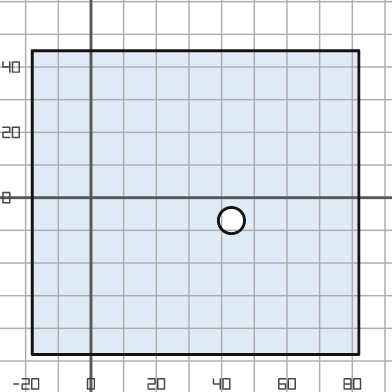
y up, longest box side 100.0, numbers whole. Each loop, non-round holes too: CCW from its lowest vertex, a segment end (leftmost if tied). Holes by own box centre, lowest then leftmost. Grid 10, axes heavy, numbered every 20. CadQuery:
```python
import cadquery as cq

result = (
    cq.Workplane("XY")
    .moveTo(-18.0, -48.0)
    .lineTo(82.0, -48.0)
    .lineTo(82.0, 45.0)
    .lineTo(-18.0, 45.0)
    .close()
    .moveTo(43.0, -7.0)
    .circle(4.0)
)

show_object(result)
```